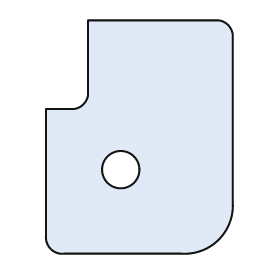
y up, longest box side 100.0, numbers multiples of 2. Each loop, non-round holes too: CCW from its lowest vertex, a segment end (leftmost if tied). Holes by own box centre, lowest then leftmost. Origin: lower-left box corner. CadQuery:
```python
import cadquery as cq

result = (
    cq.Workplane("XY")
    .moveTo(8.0, 0.0)
    .lineTo(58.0, 0.0)
    .threePointArc((74.0, 6.0), (80.0, 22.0))
    .lineTo(80.0, 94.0)
    .threePointArc((78.0, 98.0), (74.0, 100.0))
    .lineTo(18.0, 100.0)
    .lineTo(18.0, 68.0)
    .threePointArc((16.0, 64.0), (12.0, 62.0))
    .lineTo(0.0, 62.0)
    .lineTo(0.0, 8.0)
    .threePointArc((2.0, 2.0), (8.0, 0.0))
    .close()
    .moveTo(32.0, 36.0)
    .circle(8.0)
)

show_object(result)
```